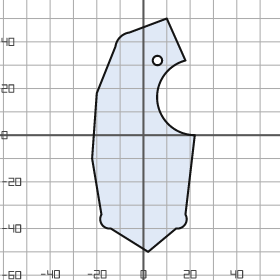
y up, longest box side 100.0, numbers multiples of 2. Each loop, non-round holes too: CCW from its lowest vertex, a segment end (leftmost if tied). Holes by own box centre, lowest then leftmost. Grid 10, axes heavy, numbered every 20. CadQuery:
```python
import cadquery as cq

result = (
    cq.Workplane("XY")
    .moveTo(2.0, -50.0)
    .lineTo(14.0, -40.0)
    .threePointArc((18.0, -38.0), (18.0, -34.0))
    .lineTo(22.0, 0.0)
    .threePointArc((6.0, 14.0), (18.0, 32.0))
    .lineTo(10.0, 50.0)
    .lineTo(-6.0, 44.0)
    .threePointArc((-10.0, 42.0), (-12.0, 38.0))
    .lineTo(-20.0, 18.0)
    .lineTo(-22.0, -10.0)
    .lineTo(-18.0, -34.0)
    .threePointArc((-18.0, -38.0), (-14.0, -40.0))
    .close()
    .moveTo(6.0, 32.0)
    .circle(2.0)
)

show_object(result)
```